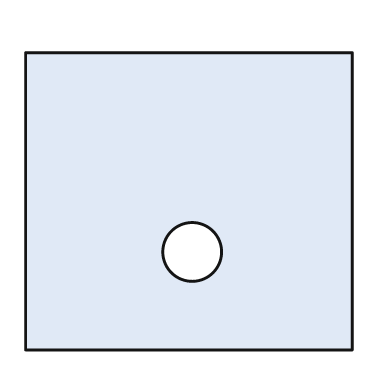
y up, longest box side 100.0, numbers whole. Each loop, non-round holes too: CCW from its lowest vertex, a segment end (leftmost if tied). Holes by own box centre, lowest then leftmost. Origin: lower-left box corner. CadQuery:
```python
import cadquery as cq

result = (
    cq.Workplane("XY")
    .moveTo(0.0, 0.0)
    .lineTo(100.0, 0.0)
    .lineTo(100.0, 91.0)
    .lineTo(0.0, 91.0)
    .close()
    .moveTo(51.0, 30.0)
    .circle(9.0)
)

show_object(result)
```